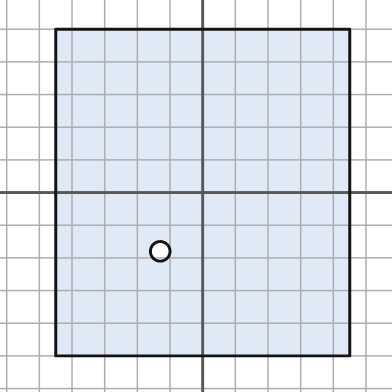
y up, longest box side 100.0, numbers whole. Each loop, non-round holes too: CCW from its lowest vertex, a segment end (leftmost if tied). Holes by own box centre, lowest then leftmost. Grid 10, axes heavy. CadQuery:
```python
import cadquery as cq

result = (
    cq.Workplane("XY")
    .moveTo(-45.0, -50.0)
    .lineTo(45.0, -50.0)
    .lineTo(45.0, 50.0)
    .lineTo(-45.0, 50.0)
    .close()
    .moveTo(-13.0, -18.0)
    .circle(3.0)
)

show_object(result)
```